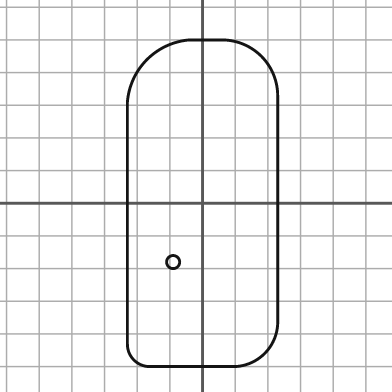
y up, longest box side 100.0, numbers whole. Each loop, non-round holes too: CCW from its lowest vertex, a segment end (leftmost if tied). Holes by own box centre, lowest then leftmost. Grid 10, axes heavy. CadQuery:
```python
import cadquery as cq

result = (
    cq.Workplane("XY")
    .moveTo(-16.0, -50.0)
    .lineTo(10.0, -50.0)
    .threePointArc((19.0, -46.0), (23.0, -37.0))
    .lineTo(23.0, 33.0)
    .threePointArc((18.0, 45.0), (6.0, 50.0))
    .lineTo(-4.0, 50.0)
    .threePointArc((-17.0, 44.0), (-23.0, 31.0))
    .lineTo(-23.0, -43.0)
    .threePointArc((-21.0, -48.0), (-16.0, -50.0))
    .close()
    .moveTo(-9.0, -18.0)
    .circle(2.0)
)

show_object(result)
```